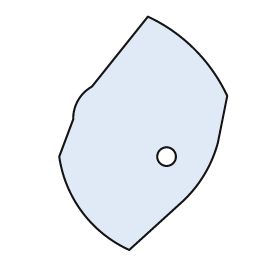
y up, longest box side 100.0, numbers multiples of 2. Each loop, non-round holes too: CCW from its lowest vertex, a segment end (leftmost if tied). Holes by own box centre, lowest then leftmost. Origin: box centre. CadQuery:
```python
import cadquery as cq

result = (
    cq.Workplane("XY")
    .moveTo(-6.0, -50.0)
    .lineTo(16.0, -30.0)
    .threePointArc((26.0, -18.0), (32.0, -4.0))
    .lineTo(36.0, 16.0)
    .threePointArc((22.0, 36.0), (2.0, 50.0))
    .lineTo(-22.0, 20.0)
    .threePointArc((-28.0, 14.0), (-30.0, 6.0))
    .lineTo(-36.0, -10.0)
    .threePointArc((-26.0, -34.0), (-6.0, -50.0))
    .close()
    .moveTo(10.0, -10.0)
    .circle(4.0)
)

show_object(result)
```